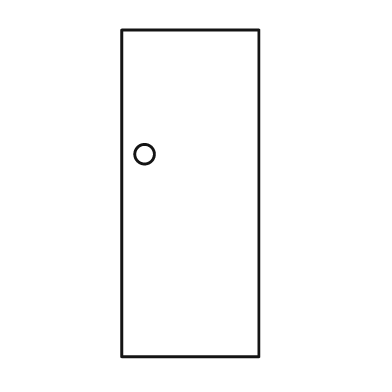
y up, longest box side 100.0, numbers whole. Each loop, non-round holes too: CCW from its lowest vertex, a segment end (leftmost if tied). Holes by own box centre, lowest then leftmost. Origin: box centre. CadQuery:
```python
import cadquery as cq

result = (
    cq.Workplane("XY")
    .moveTo(-21.0, -50.0)
    .lineTo(21.0, -50.0)
    .lineTo(21.0, 50.0)
    .lineTo(-21.0, 50.0)
    .close()
    .moveTo(-14.0, 12.0)
    .circle(3.0)
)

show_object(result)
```